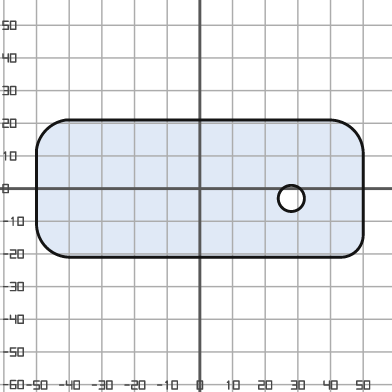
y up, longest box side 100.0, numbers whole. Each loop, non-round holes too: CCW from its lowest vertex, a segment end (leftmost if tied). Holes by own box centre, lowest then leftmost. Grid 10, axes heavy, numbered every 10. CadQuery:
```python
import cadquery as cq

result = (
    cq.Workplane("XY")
    .moveTo(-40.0, -21.0)
    .lineTo(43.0, -21.0)
    .threePointArc((48.0, -19.0), (50.0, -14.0))
    .lineTo(50.0, 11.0)
    .threePointArc((47.0, 18.0), (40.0, 21.0))
    .lineTo(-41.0, 21.0)
    .threePointArc((-47.0, 18.0), (-50.0, 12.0))
    .lineTo(-50.0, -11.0)
    .threePointArc((-47.0, -18.0), (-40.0, -21.0))
    .close()
    .moveTo(28.0, -3.0)
    .circle(4.0)
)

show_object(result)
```